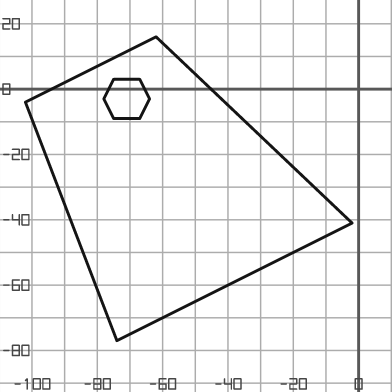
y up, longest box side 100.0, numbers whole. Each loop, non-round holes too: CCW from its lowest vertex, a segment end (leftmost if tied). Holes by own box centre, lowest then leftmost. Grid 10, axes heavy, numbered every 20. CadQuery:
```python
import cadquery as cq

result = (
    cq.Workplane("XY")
    .moveTo(-74.0, -77.0)
    .lineTo(-2.0, -41.0)
    .lineTo(-62.0, 16.0)
    .lineTo(-102.0, -4.0)
    .close()
    .moveTo(-75.0, -9.0)
    .lineTo(-67.0, -9.0)
    .lineTo(-64.0, -3.0)
    .lineTo(-67.0, 3.0)
    .lineTo(-75.0, 3.0)
    .lineTo(-78.0, -3.0)
    .close()
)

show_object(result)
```